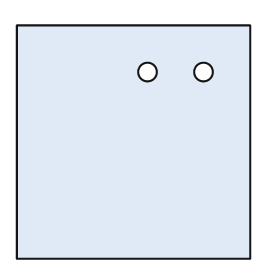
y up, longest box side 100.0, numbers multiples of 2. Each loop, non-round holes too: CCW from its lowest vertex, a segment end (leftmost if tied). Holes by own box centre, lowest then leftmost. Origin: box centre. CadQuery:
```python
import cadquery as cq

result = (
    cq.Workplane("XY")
    .moveTo(-50.0, -50.0)
    .lineTo(50.0, -50.0)
    .lineTo(50.0, 50.0)
    .lineTo(-50.0, 50.0)
    .close()
    .moveTo(6.0, 30.0)
    .circle(4.0)
    .moveTo(30.0, 30.0)
    .circle(4.0)
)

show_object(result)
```